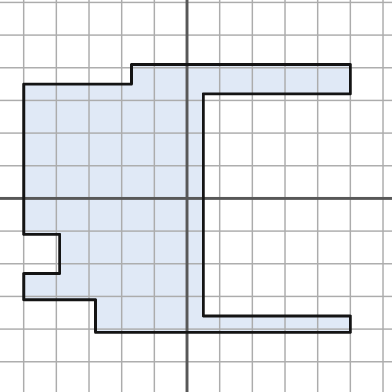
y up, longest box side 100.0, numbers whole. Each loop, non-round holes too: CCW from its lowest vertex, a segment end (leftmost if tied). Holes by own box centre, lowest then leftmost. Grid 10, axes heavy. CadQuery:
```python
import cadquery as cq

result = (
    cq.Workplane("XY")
    .moveTo(-28.0, -41.0)
    .lineTo(50.0, -41.0)
    .lineTo(50.0, -36.0)
    .lineTo(5.0, -36.0)
    .lineTo(5.0, 32.0)
    .lineTo(50.0, 32.0)
    .lineTo(50.0, 41.0)
    .lineTo(-17.0, 41.0)
    .lineTo(-17.0, 35.0)
    .lineTo(-50.0, 35.0)
    .lineTo(-50.0, -11.0)
    .lineTo(-39.0, -11.0)
    .lineTo(-39.0, -23.0)
    .lineTo(-50.0, -23.0)
    .lineTo(-50.0, -31.0)
    .lineTo(-28.0, -31.0)
    .close()
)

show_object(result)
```